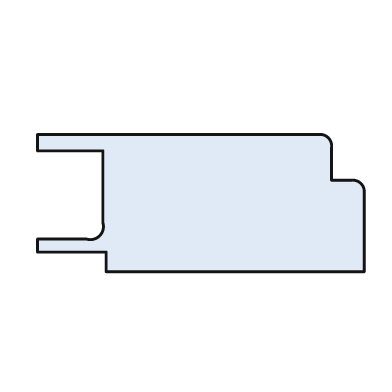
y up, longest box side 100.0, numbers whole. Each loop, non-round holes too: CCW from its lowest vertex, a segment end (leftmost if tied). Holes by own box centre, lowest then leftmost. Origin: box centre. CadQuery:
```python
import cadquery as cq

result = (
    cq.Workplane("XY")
    .moveTo(-29.0, -21.0)
    .lineTo(50.0, -21.0)
    .lineTo(50.0, 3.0)
    .threePointArc((49.0, 6.0), (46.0, 7.0))
    .lineTo(40.0, 7.0)
    .lineTo(40.0, 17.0)
    .threePointArc((39.0, 20.0), (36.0, 21.0))
    .lineTo(-50.0, 21.0)
    .lineTo(-50.0, 16.0)
    .lineTo(-30.0, 16.0)
    .lineTo(-30.0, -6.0)
    .threePointArc((-31.0, -10.0), (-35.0, -11.0))
    .lineTo(-50.0, -11.0)
    .lineTo(-50.0, -15.0)
    .lineTo(-29.0, -15.0)
    .close()
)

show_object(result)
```